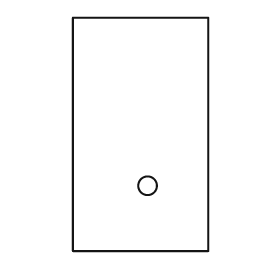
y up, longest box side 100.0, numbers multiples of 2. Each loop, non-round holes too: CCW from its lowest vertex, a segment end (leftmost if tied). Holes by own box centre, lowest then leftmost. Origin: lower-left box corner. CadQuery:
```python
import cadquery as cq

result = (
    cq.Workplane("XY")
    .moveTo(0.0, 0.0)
    .lineTo(58.0, 0.0)
    .lineTo(58.0, 100.0)
    .lineTo(0.0, 100.0)
    .close()
    .moveTo(32.0, 28.0)
    .circle(4.0)
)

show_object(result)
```